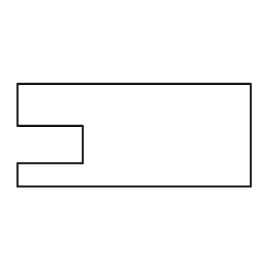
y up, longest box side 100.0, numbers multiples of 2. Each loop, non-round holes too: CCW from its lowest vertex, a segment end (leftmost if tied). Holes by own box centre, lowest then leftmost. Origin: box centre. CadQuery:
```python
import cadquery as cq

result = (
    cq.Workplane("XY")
    .moveTo(-50.0, -22.0)
    .lineTo(50.0, -22.0)
    .lineTo(50.0, 22.0)
    .lineTo(-50.0, 22.0)
    .lineTo(-50.0, 4.0)
    .lineTo(-22.0, 4.0)
    .lineTo(-22.0, -12.0)
    .lineTo(-50.0, -12.0)
    .close()
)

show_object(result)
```